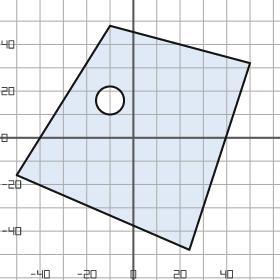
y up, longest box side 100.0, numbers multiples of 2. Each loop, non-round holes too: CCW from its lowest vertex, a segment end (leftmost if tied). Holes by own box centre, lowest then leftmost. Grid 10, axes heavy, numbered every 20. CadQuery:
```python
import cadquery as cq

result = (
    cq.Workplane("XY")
    .moveTo(24.0, -48.0)
    .lineTo(50.0, 32.0)
    .lineTo(-10.0, 48.0)
    .lineTo(-50.0, -16.0)
    .close()
    .moveTo(-10.0, 16.0)
    .circle(6.0)
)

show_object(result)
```